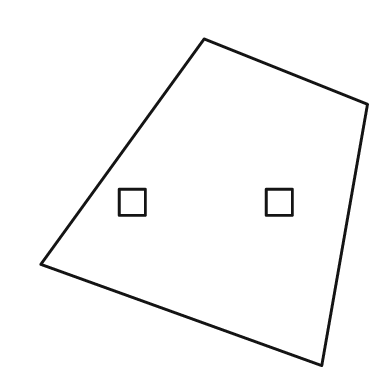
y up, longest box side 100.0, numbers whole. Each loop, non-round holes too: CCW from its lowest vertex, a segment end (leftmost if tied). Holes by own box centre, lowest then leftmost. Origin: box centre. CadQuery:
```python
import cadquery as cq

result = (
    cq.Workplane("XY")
    .moveTo(36.0, -50.0)
    .lineTo(50.0, 30.0)
    .lineTo(0.0, 50.0)
    .lineTo(-50.0, -19.0)
    .close()
    .moveTo(-26.0, -4.0)
    .lineTo(-18.0, -4.0)
    .lineTo(-18.0, 4.0)
    .lineTo(-26.0, 4.0)
    .close()
    .moveTo(19.0, -4.0)
    .lineTo(27.0, -4.0)
    .lineTo(27.0, 4.0)
    .lineTo(19.0, 4.0)
    .close()
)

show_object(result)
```